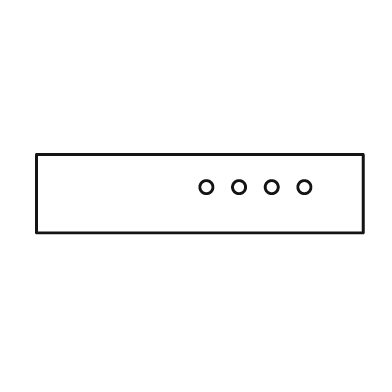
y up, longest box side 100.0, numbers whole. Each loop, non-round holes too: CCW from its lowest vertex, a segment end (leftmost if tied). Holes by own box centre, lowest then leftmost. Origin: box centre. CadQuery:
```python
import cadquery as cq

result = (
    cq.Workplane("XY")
    .moveTo(-50.0, -12.0)
    .lineTo(50.0, -12.0)
    .lineTo(50.0, 12.0)
    .lineTo(-50.0, 12.0)
    .close()
    .moveTo(2.0, 2.0)
    .circle(2.0)
    .moveTo(12.0, 2.0)
    .circle(2.0)
    .moveTo(22.0, 2.0)
    .circle(2.0)
    .moveTo(32.0, 2.0)
    .circle(2.0)
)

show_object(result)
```